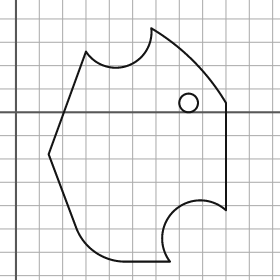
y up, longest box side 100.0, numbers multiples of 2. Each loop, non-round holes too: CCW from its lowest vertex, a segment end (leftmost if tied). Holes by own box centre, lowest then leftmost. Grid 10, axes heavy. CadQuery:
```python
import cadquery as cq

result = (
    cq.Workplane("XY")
    .moveTo(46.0, -64.0)
    .lineTo(66.0, -64.0)
    .threePointArc((68.0, -42.0), (90.0, -42.0))
    .lineTo(90.0, 4.0)
    .threePointArc((76.0, 22.0), (58.0, 36.0))
    .threePointArc((48.0, 20.0), (30.0, 26.0))
    .lineTo(14.0, -18.0)
    .lineTo(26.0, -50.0)
    .threePointArc((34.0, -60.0), (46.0, -64.0))
    .close()
    .moveTo(74.0, 4.0)
    .circle(4.0)
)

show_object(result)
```